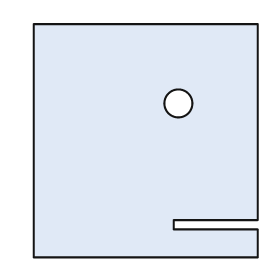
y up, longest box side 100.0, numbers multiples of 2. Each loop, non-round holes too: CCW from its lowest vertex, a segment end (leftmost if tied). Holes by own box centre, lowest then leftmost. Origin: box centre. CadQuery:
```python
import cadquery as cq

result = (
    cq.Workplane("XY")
    .moveTo(-48.0, -50.0)
    .lineTo(48.0, -50.0)
    .lineTo(48.0, -38.0)
    .lineTo(12.0, -38.0)
    .lineTo(12.0, -34.0)
    .lineTo(48.0, -34.0)
    .lineTo(48.0, 50.0)
    .lineTo(-48.0, 50.0)
    .close()
    .moveTo(14.0, 16.0)
    .circle(6.0)
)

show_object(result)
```